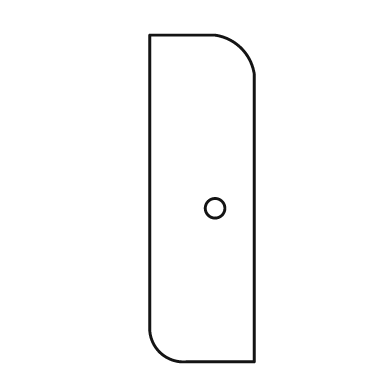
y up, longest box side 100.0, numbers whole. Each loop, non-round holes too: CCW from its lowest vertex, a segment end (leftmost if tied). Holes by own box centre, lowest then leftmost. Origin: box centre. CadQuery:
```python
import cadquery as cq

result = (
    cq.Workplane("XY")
    .moveTo(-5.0, -50.0)
    .lineTo(16.0, -50.0)
    .lineTo(16.0, 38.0)
    .threePointArc((12.0, 46.0), (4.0, 50.0))
    .lineTo(-16.0, 50.0)
    .lineTo(-16.0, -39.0)
    .threePointArc((-13.0, -47.0), (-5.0, -50.0))
    .close()
    .moveTo(4.0, -3.0)
    .circle(3.0)
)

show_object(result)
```